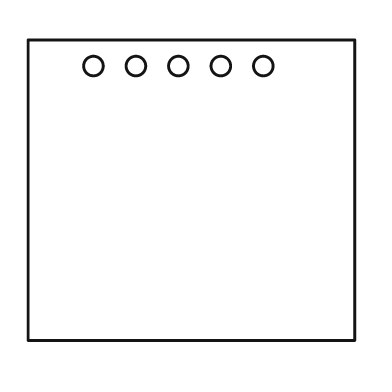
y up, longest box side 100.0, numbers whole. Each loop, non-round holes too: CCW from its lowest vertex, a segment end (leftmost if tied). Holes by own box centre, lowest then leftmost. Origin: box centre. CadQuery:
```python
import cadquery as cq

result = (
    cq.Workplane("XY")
    .moveTo(-50.0, -46.0)
    .lineTo(50.0, -46.0)
    .lineTo(50.0, 46.0)
    .lineTo(-50.0, 46.0)
    .close()
    .moveTo(-30.0, 38.0)
    .circle(3.0)
    .moveTo(-17.0, 38.0)
    .circle(3.0)
    .moveTo(-4.0, 38.0)
    .circle(3.0)
    .moveTo(9.0, 38.0)
    .circle(3.0)
    .moveTo(22.0, 38.0)
    .circle(3.0)
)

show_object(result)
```